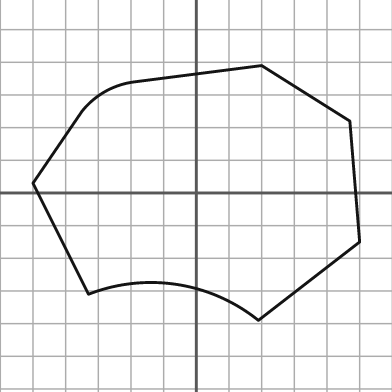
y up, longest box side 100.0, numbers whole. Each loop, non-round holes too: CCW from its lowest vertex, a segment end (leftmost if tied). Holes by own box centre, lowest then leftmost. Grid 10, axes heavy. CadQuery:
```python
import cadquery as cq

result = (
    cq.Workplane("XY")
    .moveTo(19.0, -39.0)
    .lineTo(50.0, -15.0)
    .lineTo(47.0, 22.0)
    .lineTo(20.0, 39.0)
    .lineTo(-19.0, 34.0)
    .threePointArc((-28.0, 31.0), (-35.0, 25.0))
    .lineTo(-50.0, 3.0)
    .lineTo(-33.0, -31.0)
    .threePointArc((-6.0, -28.0), (19.0, -39.0))
    .close()
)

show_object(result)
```